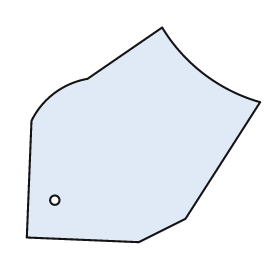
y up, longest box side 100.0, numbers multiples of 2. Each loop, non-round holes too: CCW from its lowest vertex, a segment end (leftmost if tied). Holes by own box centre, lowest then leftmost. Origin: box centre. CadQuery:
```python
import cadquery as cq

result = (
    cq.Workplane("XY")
    .moveTo(-2.0, -46.0)
    .lineTo(18.0, -36.0)
    .lineTo(50.0, 14.0)
    .threePointArc((26.0, 26.0), (8.0, 46.0))
    .lineTo(-24.0, 24.0)
    .threePointArc((-38.0, 18.0), (-48.0, 6.0))
    .lineTo(-50.0, -44.0)
    .close()
    .moveTo(-38.0, -28.0)
    .circle(2.0)
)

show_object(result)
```